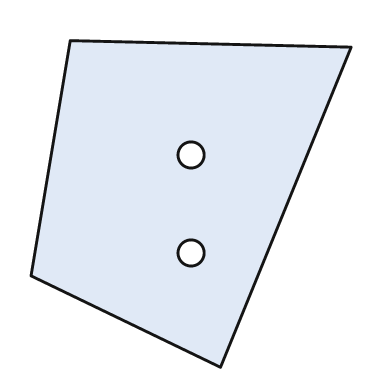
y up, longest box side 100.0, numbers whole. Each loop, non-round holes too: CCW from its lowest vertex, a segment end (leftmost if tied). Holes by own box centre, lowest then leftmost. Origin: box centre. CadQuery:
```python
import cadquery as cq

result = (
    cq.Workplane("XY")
    .moveTo(9.0, -50.0)
    .lineTo(49.0, 48.0)
    .lineTo(-37.0, 50.0)
    .lineTo(-49.0, -22.0)
    .close()
    .moveTo(0.0, -15.0)
    .circle(4.0)
    .moveTo(0.0, 15.0)
    .circle(4.0)
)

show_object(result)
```